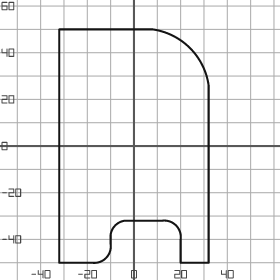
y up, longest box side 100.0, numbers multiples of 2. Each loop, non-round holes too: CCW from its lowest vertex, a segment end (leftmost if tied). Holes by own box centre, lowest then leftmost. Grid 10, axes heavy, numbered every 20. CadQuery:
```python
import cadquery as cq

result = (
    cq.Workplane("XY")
    .moveTo(-32.0, -50.0)
    .lineTo(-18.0, -50.0)
    .threePointArc((-12.0, -48.0), (-10.0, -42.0))
    .lineTo(-10.0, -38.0)
    .threePointArc((-8.0, -34.0), (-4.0, -32.0))
    .lineTo(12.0, -32.0)
    .threePointArc((18.0, -34.0), (20.0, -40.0))
    .lineTo(20.0, -50.0)
    .lineTo(32.0, -50.0)
    .lineTo(32.0, 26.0)
    .threePointArc((24.0, 42.0), (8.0, 50.0))
    .lineTo(-32.0, 50.0)
    .close()
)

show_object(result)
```